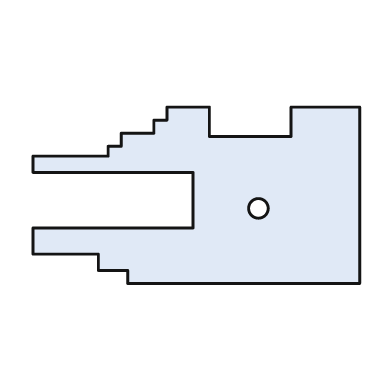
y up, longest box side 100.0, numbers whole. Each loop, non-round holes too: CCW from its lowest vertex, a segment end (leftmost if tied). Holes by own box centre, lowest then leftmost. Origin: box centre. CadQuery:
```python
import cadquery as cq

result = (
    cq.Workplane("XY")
    .moveTo(-21.0, -27.0)
    .lineTo(50.0, -27.0)
    .lineTo(50.0, 27.0)
    .lineTo(29.0, 27.0)
    .lineTo(29.0, 18.0)
    .lineTo(4.0, 18.0)
    .lineTo(4.0, 27.0)
    .lineTo(-9.0, 27.0)
    .lineTo(-9.0, 23.0)
    .lineTo(-13.0, 23.0)
    .lineTo(-13.0, 19.0)
    .lineTo(-23.0, 19.0)
    .lineTo(-23.0, 15.0)
    .lineTo(-27.0, 15.0)
    .lineTo(-27.0, 12.0)
    .lineTo(-50.0, 12.0)
    .lineTo(-50.0, 7.0)
    .lineTo(-1.0, 7.0)
    .lineTo(-1.0, -10.0)
    .lineTo(-50.0, -10.0)
    .lineTo(-50.0, -18.0)
    .lineTo(-30.0, -18.0)
    .lineTo(-30.0, -23.0)
    .lineTo(-21.0, -23.0)
    .close()
    .moveTo(19.0, -4.0)
    .circle(3.0)
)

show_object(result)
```